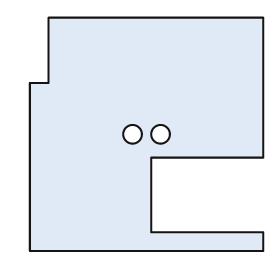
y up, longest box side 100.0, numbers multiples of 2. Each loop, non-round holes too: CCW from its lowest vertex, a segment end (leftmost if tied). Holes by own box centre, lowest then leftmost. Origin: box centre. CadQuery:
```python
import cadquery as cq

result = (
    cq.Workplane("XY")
    .moveTo(-50.0, -50.0)
    .lineTo(50.0, -50.0)
    .lineTo(50.0, -42.0)
    .lineTo(2.0, -42.0)
    .lineTo(2.0, -10.0)
    .lineTo(50.0, -10.0)
    .lineTo(50.0, 50.0)
    .lineTo(-42.0, 50.0)
    .lineTo(-42.0, 22.0)
    .lineTo(-50.0, 22.0)
    .close()
    .moveTo(-6.0, 0.0)
    .circle(4.0)
    .moveTo(6.0, 0.0)
    .circle(4.0)
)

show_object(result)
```